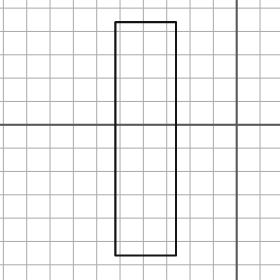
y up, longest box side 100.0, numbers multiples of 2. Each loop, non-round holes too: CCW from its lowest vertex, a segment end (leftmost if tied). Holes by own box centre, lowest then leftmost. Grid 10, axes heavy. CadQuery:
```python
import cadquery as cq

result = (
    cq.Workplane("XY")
    .moveTo(-52.0, -56.0)
    .lineTo(-26.0, -56.0)
    .lineTo(-26.0, 44.0)
    .lineTo(-52.0, 44.0)
    .close()
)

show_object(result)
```